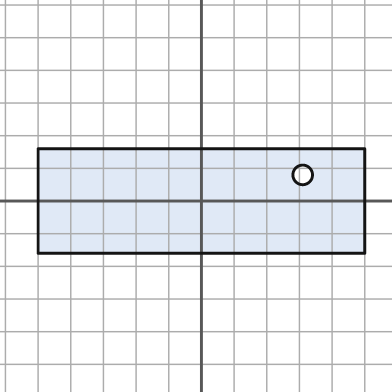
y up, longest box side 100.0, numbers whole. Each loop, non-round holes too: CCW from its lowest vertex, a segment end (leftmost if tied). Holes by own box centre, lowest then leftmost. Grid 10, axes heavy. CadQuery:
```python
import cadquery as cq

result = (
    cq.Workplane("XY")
    .moveTo(-50.0, -16.0)
    .lineTo(50.0, -16.0)
    .lineTo(50.0, 16.0)
    .lineTo(-50.0, 16.0)
    .close()
    .moveTo(31.0, 8.0)
    .circle(3.0)
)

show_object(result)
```